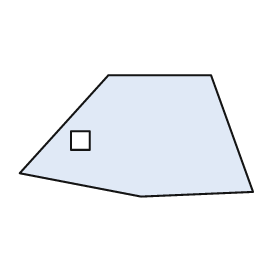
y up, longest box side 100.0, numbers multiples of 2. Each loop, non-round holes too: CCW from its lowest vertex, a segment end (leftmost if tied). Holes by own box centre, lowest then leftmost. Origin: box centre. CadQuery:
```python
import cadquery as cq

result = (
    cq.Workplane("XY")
    .moveTo(2.0, -26.0)
    .lineTo(50.0, -24.0)
    .lineTo(32.0, 26.0)
    .lineTo(-12.0, 26.0)
    .lineTo(-50.0, -16.0)
    .close()
    .moveTo(-28.0, -6.0)
    .lineTo(-20.0, -6.0)
    .lineTo(-20.0, 2.0)
    .lineTo(-28.0, 2.0)
    .close()
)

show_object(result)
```